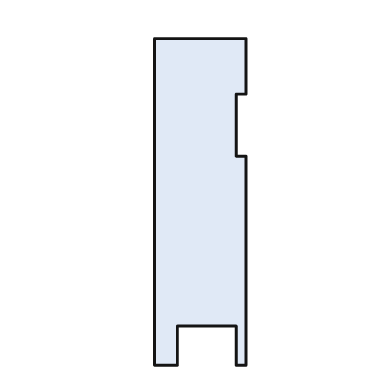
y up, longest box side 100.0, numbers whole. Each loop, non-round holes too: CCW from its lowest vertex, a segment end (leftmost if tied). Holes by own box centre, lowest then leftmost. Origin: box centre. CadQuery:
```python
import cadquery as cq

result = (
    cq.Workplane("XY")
    .moveTo(-14.0, -50.0)
    .lineTo(-7.0, -50.0)
    .lineTo(-7.0, -38.0)
    .lineTo(11.0, -38.0)
    .lineTo(11.0, -50.0)
    .lineTo(14.0, -50.0)
    .lineTo(14.0, 14.0)
    .lineTo(11.0, 14.0)
    .lineTo(11.0, 33.0)
    .lineTo(14.0, 33.0)
    .lineTo(14.0, 50.0)
    .lineTo(-14.0, 50.0)
    .close()
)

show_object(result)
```